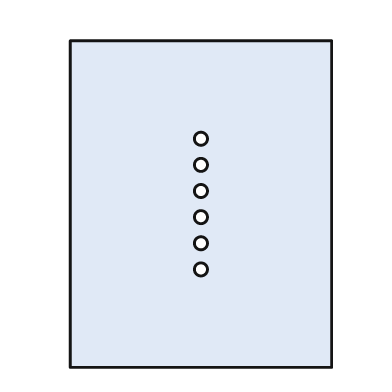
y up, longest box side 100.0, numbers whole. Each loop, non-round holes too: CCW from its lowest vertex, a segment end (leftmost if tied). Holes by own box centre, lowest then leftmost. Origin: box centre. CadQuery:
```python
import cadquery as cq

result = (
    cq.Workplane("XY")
    .moveTo(-40.0, -50.0)
    .lineTo(40.0, -50.0)
    .lineTo(40.0, 50.0)
    .lineTo(-40.0, 50.0)
    .close()
    .moveTo(0.0, -20.0)
    .circle(2.0)
    .moveTo(0.0, -12.0)
    .circle(2.0)
    .moveTo(0.0, -4.0)
    .circle(2.0)
    .moveTo(0.0, 4.0)
    .circle(2.0)
    .moveTo(0.0, 12.0)
    .circle(2.0)
    .moveTo(0.0, 20.0)
    .circle(2.0)
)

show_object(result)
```